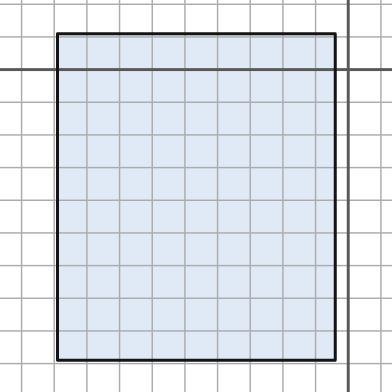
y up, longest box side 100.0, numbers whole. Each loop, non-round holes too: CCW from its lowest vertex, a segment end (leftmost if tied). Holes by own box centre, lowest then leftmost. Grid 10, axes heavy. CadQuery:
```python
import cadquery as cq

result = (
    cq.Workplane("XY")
    .moveTo(-89.0, -89.0)
    .lineTo(-4.0, -89.0)
    .lineTo(-4.0, 11.0)
    .lineTo(-89.0, 11.0)
    .close()
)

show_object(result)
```